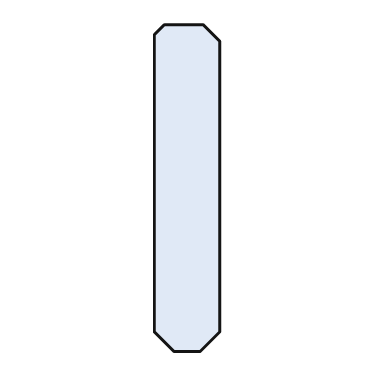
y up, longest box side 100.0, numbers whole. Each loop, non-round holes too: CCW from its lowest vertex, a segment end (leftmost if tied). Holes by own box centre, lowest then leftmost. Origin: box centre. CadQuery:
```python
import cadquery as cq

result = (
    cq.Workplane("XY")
    .moveTo(-4.0, -50.0)
    .lineTo(4.0, -50.0)
    .lineTo(10.0, -44.0)
    .lineTo(10.0, 45.0)
    .lineTo(5.0, 50.0)
    .lineTo(-7.0, 50.0)
    .lineTo(-10.0, 47.0)
    .lineTo(-10.0, -44.0)
    .close()
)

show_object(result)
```